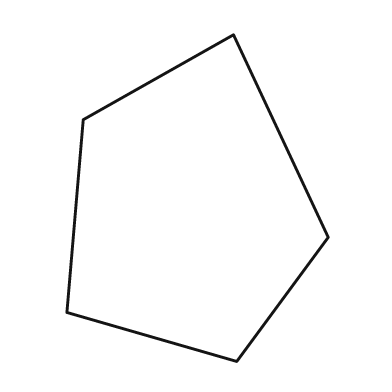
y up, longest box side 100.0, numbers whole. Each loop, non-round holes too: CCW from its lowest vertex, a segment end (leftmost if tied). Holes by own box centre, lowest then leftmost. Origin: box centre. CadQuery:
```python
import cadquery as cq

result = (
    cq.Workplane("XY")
    .moveTo(12.0, -50.0)
    .lineTo(40.0, -12.0)
    .lineTo(11.0, 50.0)
    .lineTo(-35.0, 24.0)
    .lineTo(-40.0, -35.0)
    .close()
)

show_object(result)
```